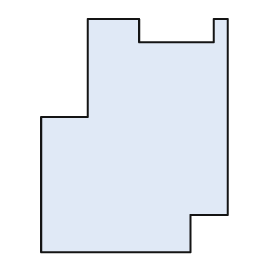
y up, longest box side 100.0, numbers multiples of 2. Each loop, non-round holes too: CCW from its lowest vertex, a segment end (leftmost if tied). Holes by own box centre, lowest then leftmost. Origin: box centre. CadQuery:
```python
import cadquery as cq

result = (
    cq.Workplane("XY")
    .moveTo(-40.0, -50.0)
    .lineTo(24.0, -50.0)
    .lineTo(24.0, -34.0)
    .lineTo(40.0, -34.0)
    .lineTo(40.0, 50.0)
    .lineTo(34.0, 50.0)
    .lineTo(34.0, 40.0)
    .lineTo(2.0, 40.0)
    .lineTo(2.0, 50.0)
    .lineTo(-20.0, 50.0)
    .lineTo(-20.0, 8.0)
    .lineTo(-40.0, 8.0)
    .close()
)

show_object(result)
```